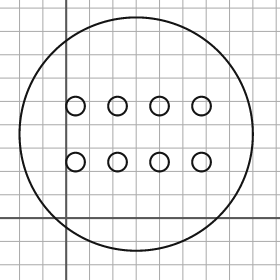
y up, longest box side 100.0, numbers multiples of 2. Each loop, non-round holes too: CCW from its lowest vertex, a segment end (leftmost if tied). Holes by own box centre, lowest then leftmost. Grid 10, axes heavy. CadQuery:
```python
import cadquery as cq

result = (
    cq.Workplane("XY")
    .moveTo(30.0, 36.0)
    .circle(50.0)
    .moveTo(4.0, 24.0)
    .circle(4.0)
    .moveTo(22.0, 24.0)
    .circle(4.0)
    .moveTo(40.0, 24.0)
    .circle(4.0)
    .moveTo(58.0, 24.0)
    .circle(4.0)
    .moveTo(4.0, 48.0)
    .circle(4.0)
    .moveTo(22.0, 48.0)
    .circle(4.0)
    .moveTo(40.0, 48.0)
    .circle(4.0)
    .moveTo(58.0, 48.0)
    .circle(4.0)
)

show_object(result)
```